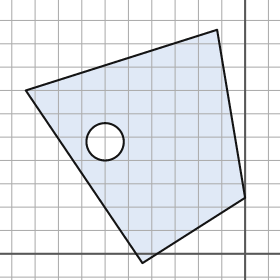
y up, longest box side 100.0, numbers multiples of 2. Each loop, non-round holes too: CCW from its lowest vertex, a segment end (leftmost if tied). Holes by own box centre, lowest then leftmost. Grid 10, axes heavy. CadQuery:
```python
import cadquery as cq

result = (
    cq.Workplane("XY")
    .moveTo(-44.0, -4.0)
    .lineTo(0.0, 24.0)
    .lineTo(-12.0, 96.0)
    .lineTo(-94.0, 70.0)
    .close()
    .moveTo(-60.0, 48.0)
    .circle(8.0)
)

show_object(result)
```